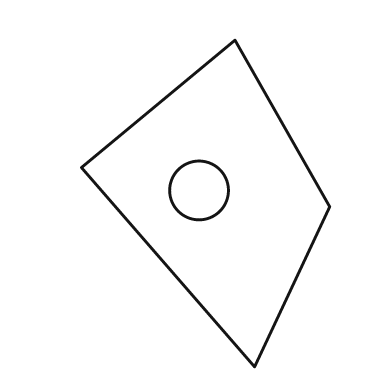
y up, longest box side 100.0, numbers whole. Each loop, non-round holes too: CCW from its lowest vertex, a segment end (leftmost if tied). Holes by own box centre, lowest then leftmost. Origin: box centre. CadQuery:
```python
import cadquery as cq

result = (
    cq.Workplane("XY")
    .moveTo(15.0, -50.0)
    .lineTo(38.0, -1.0)
    .lineTo(9.0, 50.0)
    .lineTo(-38.0, 11.0)
    .close()
    .moveTo(-2.0, 4.0)
    .circle(9.0)
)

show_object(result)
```